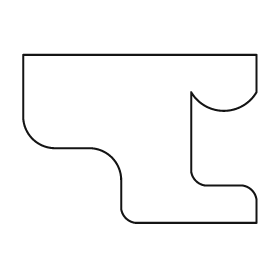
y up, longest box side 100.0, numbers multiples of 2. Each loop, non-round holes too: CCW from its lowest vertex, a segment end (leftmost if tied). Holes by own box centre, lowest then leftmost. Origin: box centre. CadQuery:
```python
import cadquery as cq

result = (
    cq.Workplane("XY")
    .moveTo(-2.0, -36.0)
    .lineTo(50.0, -36.0)
    .lineTo(50.0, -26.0)
    .threePointArc((48.0, -22.0), (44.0, -20.0))
    .lineTo(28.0, -20.0)
    .threePointArc((24.0, -18.0), (22.0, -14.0))
    .lineTo(22.0, 20.0)
    .threePointArc((36.0, 12.0), (50.0, 20.0))
    .lineTo(50.0, 36.0)
    .lineTo(-50.0, 36.0)
    .lineTo(-50.0, 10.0)
    .threePointArc((-46.0, 0.0), (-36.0, -4.0))
    .lineTo(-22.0, -4.0)
    .threePointArc((-12.0, -8.0), (-8.0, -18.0))
    .lineTo(-8.0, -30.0)
    .threePointArc((-6.0, -34.0), (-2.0, -36.0))
    .close()
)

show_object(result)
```